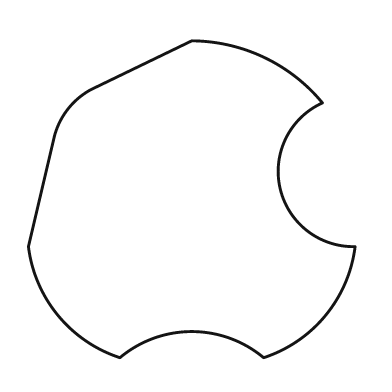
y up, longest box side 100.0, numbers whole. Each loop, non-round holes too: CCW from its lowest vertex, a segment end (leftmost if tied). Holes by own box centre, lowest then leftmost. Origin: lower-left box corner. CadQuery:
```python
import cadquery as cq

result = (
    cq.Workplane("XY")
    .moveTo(28.0, 0.0)
    .threePointArc((50.0, 8.0), (72.0, 0.0))
    .threePointArc((91.0, 13.0), (100.0, 34.0))
    .threePointArc((77.0, 52.0), (90.0, 78.0))
    .threePointArc((72.0, 92.0), (50.0, 97.0))
    .lineTo(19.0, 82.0)
    .threePointArc((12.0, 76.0), (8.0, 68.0))
    .lineTo(0.0, 34.0)
    .threePointArc((9.0, 13.0), (28.0, 0.0))
    .close()
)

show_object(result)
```